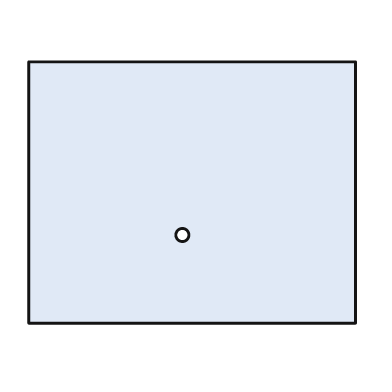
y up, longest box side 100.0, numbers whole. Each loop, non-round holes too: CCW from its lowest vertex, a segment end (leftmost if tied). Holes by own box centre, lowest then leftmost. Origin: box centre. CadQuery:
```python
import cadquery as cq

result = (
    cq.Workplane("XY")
    .moveTo(-50.0, -40.0)
    .lineTo(50.0, -40.0)
    .lineTo(50.0, 40.0)
    .lineTo(-50.0, 40.0)
    .close()
    .moveTo(-3.0, -13.0)
    .circle(2.0)
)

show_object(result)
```